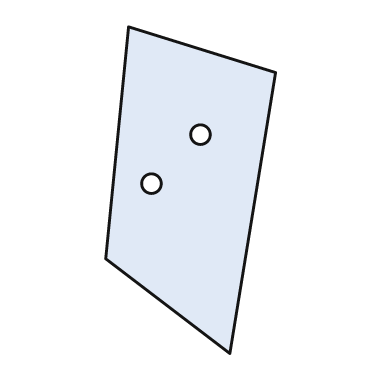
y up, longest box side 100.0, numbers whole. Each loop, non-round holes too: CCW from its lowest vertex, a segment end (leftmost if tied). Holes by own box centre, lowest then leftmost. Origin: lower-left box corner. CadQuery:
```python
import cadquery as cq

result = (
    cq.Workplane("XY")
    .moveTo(38.0, 0.0)
    .lineTo(52.0, 86.0)
    .lineTo(7.0, 100.0)
    .lineTo(0.0, 29.0)
    .close()
    .moveTo(14.0, 52.0)
    .circle(3.0)
    .moveTo(29.0, 67.0)
    .circle(3.0)
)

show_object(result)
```